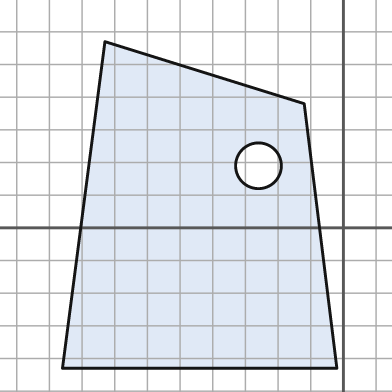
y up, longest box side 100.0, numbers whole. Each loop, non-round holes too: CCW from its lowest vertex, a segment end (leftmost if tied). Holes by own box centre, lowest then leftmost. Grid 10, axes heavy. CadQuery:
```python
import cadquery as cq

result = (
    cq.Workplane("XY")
    .moveTo(-86.0, -43.0)
    .lineTo(-2.0, -43.0)
    .lineTo(-12.0, 38.0)
    .lineTo(-73.0, 57.0)
    .close()
    .moveTo(-26.0, 19.0)
    .circle(7.0)
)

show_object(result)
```